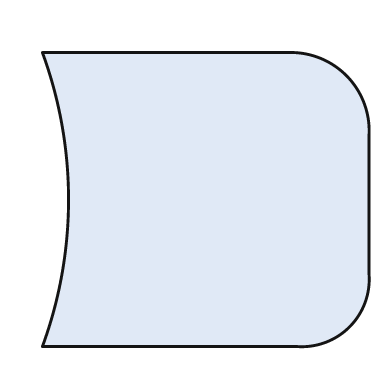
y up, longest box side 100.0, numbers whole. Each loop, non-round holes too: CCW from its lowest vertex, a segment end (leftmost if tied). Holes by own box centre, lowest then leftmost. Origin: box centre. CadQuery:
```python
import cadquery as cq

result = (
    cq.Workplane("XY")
    .moveTo(-50.0, -45.0)
    .lineTo(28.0, -45.0)
    .threePointArc((44.0, -39.0), (50.0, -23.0))
    .lineTo(50.0, 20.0)
    .threePointArc((43.0, 38.0), (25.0, 45.0))
    .lineTo(-50.0, 45.0)
    .threePointArc((-42.0, 0.0), (-50.0, -45.0))
    .close()
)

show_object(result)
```